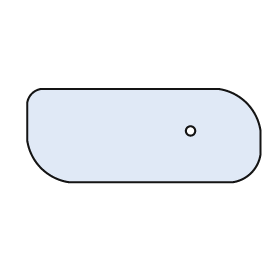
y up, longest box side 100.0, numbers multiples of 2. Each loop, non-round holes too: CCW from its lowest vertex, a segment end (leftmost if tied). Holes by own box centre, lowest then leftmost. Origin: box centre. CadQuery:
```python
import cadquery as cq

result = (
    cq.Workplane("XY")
    .moveTo(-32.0, -20.0)
    .lineTo(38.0, -20.0)
    .threePointArc((46.0, -16.0), (50.0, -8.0))
    .lineTo(50.0, 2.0)
    .threePointArc((44.0, 14.0), (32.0, 20.0))
    .lineTo(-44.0, 20.0)
    .threePointArc((-48.0, 18.0), (-50.0, 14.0))
    .lineTo(-50.0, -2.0)
    .threePointArc((-44.0, -14.0), (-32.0, -20.0))
    .close()
    .moveTo(20.0, 2.0)
    .circle(2.0)
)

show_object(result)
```